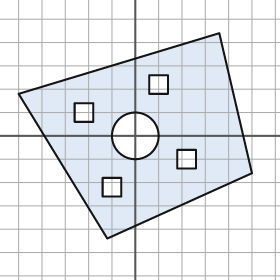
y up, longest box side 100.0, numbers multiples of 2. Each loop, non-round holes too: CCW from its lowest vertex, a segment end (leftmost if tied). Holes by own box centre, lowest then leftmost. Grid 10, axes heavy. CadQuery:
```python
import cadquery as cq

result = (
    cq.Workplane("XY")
    .moveTo(-12.0, -44.0)
    .lineTo(50.0, -16.0)
    .lineTo(36.0, 44.0)
    .lineTo(-50.0, 18.0)
    .close()
    .moveTo(-14.0, -26.0)
    .lineTo(-6.0, -26.0)
    .lineTo(-6.0, -18.0)
    .lineTo(-14.0, -18.0)
    .close()
    .moveTo(18.0, -14.0)
    .lineTo(26.0, -14.0)
    .lineTo(26.0, -6.0)
    .lineTo(18.0, -6.0)
    .close()
    .moveTo(0.0, 0.0)
    .circle(10.0)
    .moveTo(-26.0, 6.0)
    .lineTo(-18.0, 6.0)
    .lineTo(-18.0, 14.0)
    .lineTo(-26.0, 14.0)
    .close()
    .moveTo(6.0, 18.0)
    .lineTo(14.0, 18.0)
    .lineTo(14.0, 26.0)
    .lineTo(6.0, 26.0)
    .close()
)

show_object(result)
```